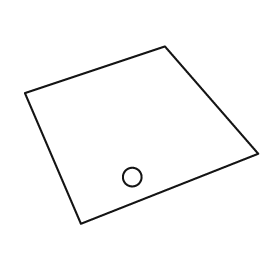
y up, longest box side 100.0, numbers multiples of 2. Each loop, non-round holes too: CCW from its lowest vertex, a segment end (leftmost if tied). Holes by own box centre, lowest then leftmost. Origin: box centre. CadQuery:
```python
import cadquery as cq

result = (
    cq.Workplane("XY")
    .moveTo(-26.0, -38.0)
    .lineTo(50.0, -8.0)
    .lineTo(10.0, 38.0)
    .lineTo(-50.0, 18.0)
    .close()
    .moveTo(-4.0, -18.0)
    .circle(4.0)
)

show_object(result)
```